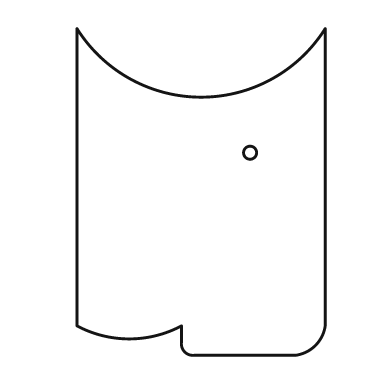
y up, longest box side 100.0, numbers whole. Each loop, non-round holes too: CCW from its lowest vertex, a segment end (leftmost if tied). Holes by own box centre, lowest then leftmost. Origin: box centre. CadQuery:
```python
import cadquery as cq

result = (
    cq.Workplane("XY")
    .moveTo(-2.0, -50.0)
    .lineTo(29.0, -50.0)
    .threePointArc((35.0, -47.0), (38.0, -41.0))
    .lineTo(38.0, 50.0)
    .threePointArc((0.0, 29.0), (-38.0, 50.0))
    .lineTo(-38.0, -41.0)
    .threePointArc((-22.0, -45.0), (-6.0, -41.0))
    .lineTo(-6.0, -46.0)
    .threePointArc((-5.0, -49.0), (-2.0, -50.0))
    .close()
    .moveTo(15.0, 12.0)
    .circle(2.0)
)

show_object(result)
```